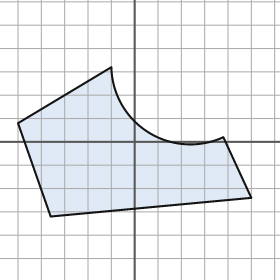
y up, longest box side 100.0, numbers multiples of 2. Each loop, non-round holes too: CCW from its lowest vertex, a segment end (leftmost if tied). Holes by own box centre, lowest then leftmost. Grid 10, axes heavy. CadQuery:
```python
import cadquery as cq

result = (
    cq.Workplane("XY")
    .moveTo(-36.0, -32.0)
    .lineTo(50.0, -24.0)
    .lineTo(38.0, 2.0)
    .threePointArc((6.0, 4.0), (-10.0, 32.0))
    .lineTo(-50.0, 8.0)
    .close()
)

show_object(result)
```